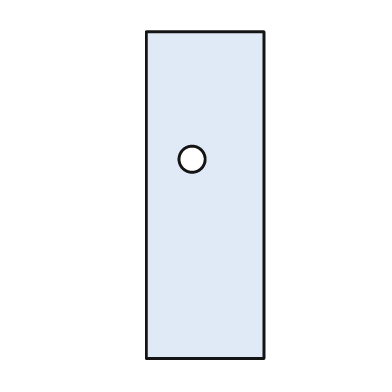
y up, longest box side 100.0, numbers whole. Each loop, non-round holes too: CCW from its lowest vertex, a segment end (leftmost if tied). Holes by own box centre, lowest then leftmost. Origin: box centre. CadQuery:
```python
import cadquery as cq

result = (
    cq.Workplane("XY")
    .moveTo(-18.0, -50.0)
    .lineTo(18.0, -50.0)
    .lineTo(18.0, 50.0)
    .lineTo(-18.0, 50.0)
    .close()
    .moveTo(-4.0, 11.0)
    .circle(4.0)
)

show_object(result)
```